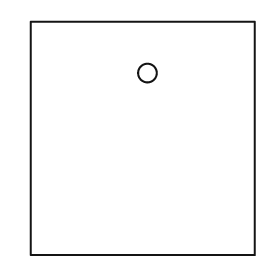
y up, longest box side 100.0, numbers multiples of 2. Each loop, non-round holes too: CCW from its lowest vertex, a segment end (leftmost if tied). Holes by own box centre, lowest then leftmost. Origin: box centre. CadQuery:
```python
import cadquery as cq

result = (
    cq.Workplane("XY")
    .moveTo(-48.0, -50.0)
    .lineTo(48.0, -50.0)
    .lineTo(48.0, 50.0)
    .lineTo(-48.0, 50.0)
    .close()
    .moveTo(2.0, 28.0)
    .circle(4.0)
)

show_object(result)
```